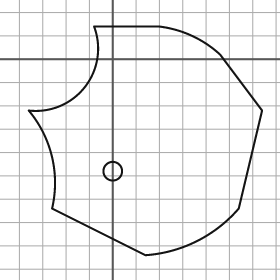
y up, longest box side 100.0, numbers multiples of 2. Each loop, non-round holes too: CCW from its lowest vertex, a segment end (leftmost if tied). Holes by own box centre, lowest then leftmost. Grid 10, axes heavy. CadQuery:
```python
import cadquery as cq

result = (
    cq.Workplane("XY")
    .moveTo(14.0, -84.0)
    .threePointArc((36.0, -78.0), (54.0, -64.0))
    .lineTo(64.0, -22.0)
    .lineTo(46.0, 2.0)
    .threePointArc((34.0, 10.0), (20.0, 14.0))
    .lineTo(-8.0, 14.0)
    .threePointArc((-12.0, -12.0), (-36.0, -22.0))
    .threePointArc((-26.0, -42.0), (-26.0, -64.0))
    .close()
    .moveTo(0.0, -48.0)
    .circle(4.0)
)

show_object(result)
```